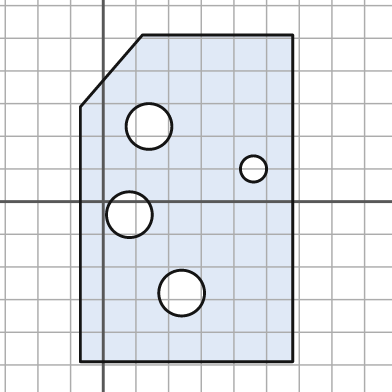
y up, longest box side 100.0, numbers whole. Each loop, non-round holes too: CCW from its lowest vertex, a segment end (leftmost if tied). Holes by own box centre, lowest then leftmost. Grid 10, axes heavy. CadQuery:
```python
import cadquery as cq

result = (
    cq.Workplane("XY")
    .moveTo(-7.0, -49.0)
    .lineTo(58.0, -49.0)
    .lineTo(58.0, 51.0)
    .lineTo(12.0, 51.0)
    .lineTo(-7.0, 29.0)
    .close()
    .moveTo(24.0, -28.0)
    .circle(7.0)
    .moveTo(8.0, -4.0)
    .circle(7.0)
    .moveTo(46.0, 10.0)
    .circle(4.0)
    .moveTo(14.0, 23.0)
    .circle(7.0)
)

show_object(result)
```